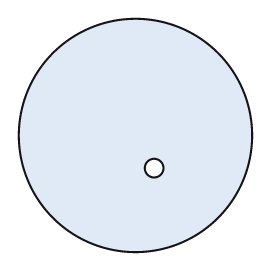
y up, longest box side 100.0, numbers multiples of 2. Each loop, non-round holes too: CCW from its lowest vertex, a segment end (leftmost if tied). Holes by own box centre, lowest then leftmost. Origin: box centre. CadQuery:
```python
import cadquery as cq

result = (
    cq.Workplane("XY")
    .moveTo(0.0, 0.0)
    .circle(50.0)
    .moveTo(8.0, -14.0)
    .circle(4.0)
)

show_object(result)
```